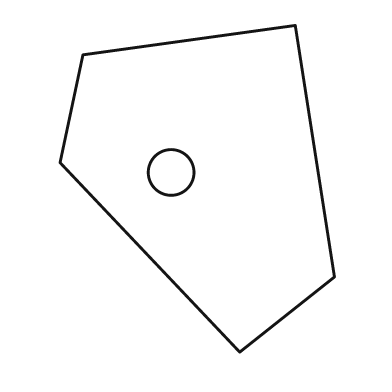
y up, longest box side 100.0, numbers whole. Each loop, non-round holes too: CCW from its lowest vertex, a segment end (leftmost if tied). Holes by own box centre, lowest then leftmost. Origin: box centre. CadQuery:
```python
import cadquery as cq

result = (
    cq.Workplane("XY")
    .moveTo(13.0, -50.0)
    .lineTo(42.0, -27.0)
    .lineTo(30.0, 50.0)
    .lineTo(-35.0, 41.0)
    .lineTo(-42.0, 8.0)
    .close()
    .moveTo(-8.0, 5.0)
    .circle(7.0)
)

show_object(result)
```